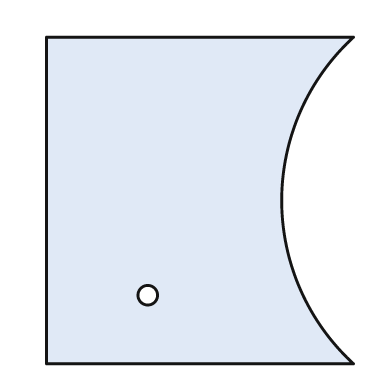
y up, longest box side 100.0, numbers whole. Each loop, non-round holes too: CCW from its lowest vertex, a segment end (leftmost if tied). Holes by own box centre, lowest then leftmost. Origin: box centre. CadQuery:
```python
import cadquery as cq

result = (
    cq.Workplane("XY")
    .moveTo(-47.0, -50.0)
    .lineTo(47.0, -50.0)
    .threePointArc((25.0, 0.0), (47.0, 50.0))
    .lineTo(-47.0, 50.0)
    .close()
    .moveTo(-16.0, -29.0)
    .circle(3.0)
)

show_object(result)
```